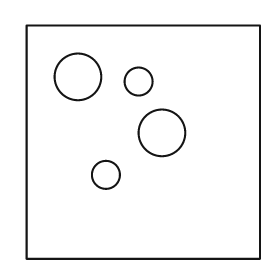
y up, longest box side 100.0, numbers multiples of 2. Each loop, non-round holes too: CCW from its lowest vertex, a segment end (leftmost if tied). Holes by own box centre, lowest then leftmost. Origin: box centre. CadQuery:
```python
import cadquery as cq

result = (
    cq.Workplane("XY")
    .moveTo(-50.0, -50.0)
    .lineTo(50.0, -50.0)
    .lineTo(50.0, 50.0)
    .lineTo(-50.0, 50.0)
    .close()
    .moveTo(-16.0, -14.0)
    .circle(6.0)
    .moveTo(8.0, 4.0)
    .circle(10.0)
    .moveTo(-2.0, 26.0)
    .circle(6.0)
    .moveTo(-28.0, 28.0)
    .circle(10.0)
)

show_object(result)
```